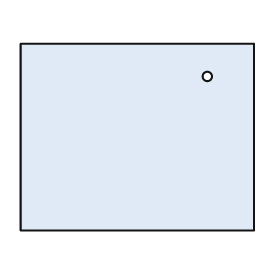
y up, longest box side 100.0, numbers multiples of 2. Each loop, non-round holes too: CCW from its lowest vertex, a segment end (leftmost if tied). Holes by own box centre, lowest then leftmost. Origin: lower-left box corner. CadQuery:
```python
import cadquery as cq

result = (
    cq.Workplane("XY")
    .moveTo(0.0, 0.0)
    .lineTo(100.0, 0.0)
    .lineTo(100.0, 80.0)
    .lineTo(0.0, 80.0)
    .close()
    .moveTo(80.0, 66.0)
    .circle(2.0)
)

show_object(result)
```